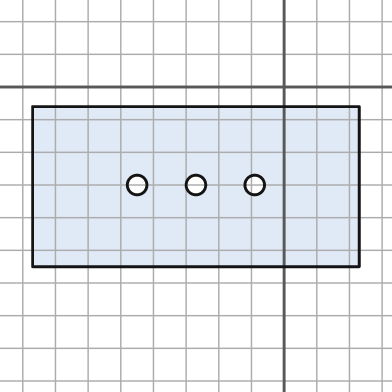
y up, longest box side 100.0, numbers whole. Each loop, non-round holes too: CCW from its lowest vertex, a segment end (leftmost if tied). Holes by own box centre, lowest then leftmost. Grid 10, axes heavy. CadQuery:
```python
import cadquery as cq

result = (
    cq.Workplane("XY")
    .moveTo(-77.0, -55.0)
    .lineTo(23.0, -55.0)
    .lineTo(23.0, -6.0)
    .lineTo(-77.0, -6.0)
    .close()
    .moveTo(-45.0, -30.0)
    .circle(3.0)
    .moveTo(-27.0, -30.0)
    .circle(3.0)
    .moveTo(-9.0, -30.0)
    .circle(3.0)
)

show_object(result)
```